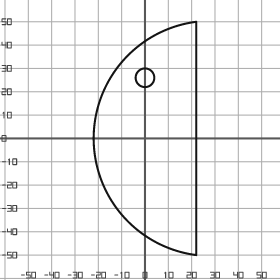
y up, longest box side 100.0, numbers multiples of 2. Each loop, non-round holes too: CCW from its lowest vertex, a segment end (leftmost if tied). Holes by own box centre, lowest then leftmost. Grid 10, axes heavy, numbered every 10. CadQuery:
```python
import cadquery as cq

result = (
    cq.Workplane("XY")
    .moveTo(22.0, -50.0)
    .lineTo(22.0, 50.0)
    .threePointArc((-22.0, 0.0), (22.0, -50.0))
    .close()
    .moveTo(0.0, 26.0)
    .circle(4.0)
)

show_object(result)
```